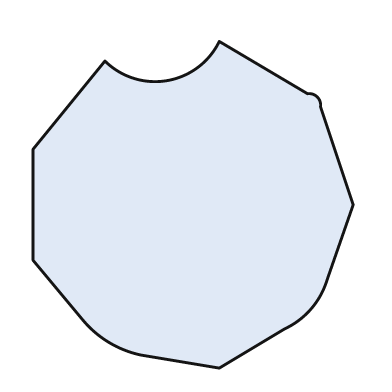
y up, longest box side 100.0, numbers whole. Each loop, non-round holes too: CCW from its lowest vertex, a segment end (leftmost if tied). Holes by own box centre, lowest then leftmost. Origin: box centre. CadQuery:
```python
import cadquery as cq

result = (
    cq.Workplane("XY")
    .moveTo(8.0, -50.0)
    .lineTo(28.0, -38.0)
    .threePointArc((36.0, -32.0), (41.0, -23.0))
    .lineTo(49.0, 0.0)
    .lineTo(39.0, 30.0)
    .threePointArc((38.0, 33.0), (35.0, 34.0))
    .lineTo(8.0, 50.0)
    .threePointArc((-8.0, 38.0), (-27.0, 44.0))
    .lineTo(-49.0, 17.0)
    .lineTo(-49.0, -17.0)
    .lineTo(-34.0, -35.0)
    .threePointArc((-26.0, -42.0), (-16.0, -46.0))
    .close()
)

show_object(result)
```